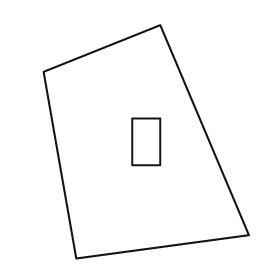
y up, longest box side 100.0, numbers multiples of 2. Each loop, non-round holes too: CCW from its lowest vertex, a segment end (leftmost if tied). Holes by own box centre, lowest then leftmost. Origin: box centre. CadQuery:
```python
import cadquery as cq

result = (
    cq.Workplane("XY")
    .moveTo(-30.0, -50.0)
    .lineTo(44.0, -40.0)
    .lineTo(6.0, 50.0)
    .lineTo(-44.0, 30.0)
    .close()
    .moveTo(-6.0, -10.0)
    .lineTo(6.0, -10.0)
    .lineTo(6.0, 10.0)
    .lineTo(-6.0, 10.0)
    .close()
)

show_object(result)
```